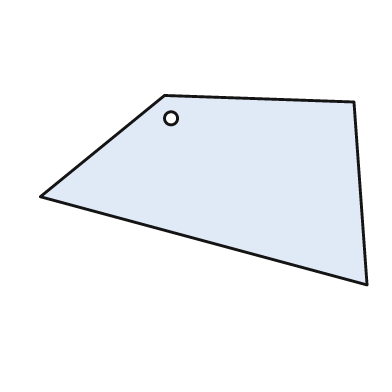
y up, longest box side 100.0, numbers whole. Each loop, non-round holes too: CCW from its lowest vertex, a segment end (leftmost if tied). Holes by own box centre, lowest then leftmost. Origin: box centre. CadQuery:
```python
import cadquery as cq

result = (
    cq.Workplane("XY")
    .moveTo(50.0, -29.0)
    .lineTo(46.0, 27.0)
    .lineTo(-12.0, 29.0)
    .lineTo(-50.0, -2.0)
    .close()
    .moveTo(-10.0, 22.0)
    .circle(2.0)
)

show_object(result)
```